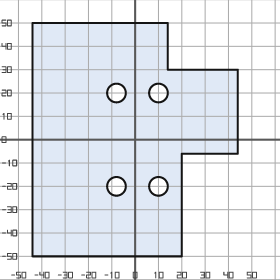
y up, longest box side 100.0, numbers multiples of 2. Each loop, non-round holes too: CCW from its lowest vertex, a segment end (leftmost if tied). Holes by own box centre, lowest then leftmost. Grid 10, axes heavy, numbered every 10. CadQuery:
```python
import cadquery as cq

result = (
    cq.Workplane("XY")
    .moveTo(-44.0, -50.0)
    .lineTo(20.0, -50.0)
    .lineTo(20.0, -6.0)
    .lineTo(44.0, -6.0)
    .lineTo(44.0, 30.0)
    .lineTo(14.0, 30.0)
    .lineTo(14.0, 50.0)
    .lineTo(-44.0, 50.0)
    .close()
    .moveTo(-8.0, -20.0)
    .circle(4.0)
    .moveTo(10.0, -20.0)
    .circle(4.0)
    .moveTo(-8.0, 20.0)
    .circle(4.0)
    .moveTo(10.0, 20.0)
    .circle(4.0)
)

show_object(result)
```